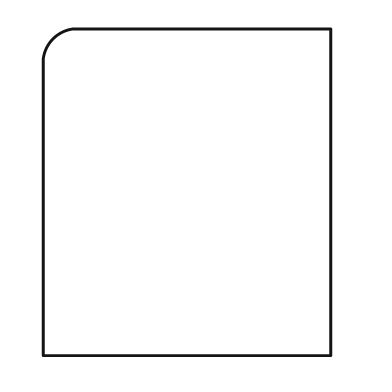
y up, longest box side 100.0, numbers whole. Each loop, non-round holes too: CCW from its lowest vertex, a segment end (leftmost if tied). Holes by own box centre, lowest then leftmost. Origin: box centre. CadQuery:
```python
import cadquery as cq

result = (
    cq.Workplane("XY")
    .moveTo(-44.0, -50.0)
    .lineTo(44.0, -50.0)
    .lineTo(44.0, 50.0)
    .lineTo(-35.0, 50.0)
    .threePointArc((-41.0, 47.0), (-44.0, 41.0))
    .close()
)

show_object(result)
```